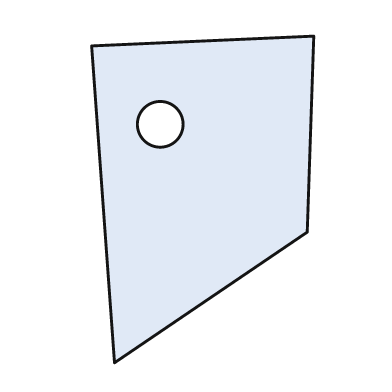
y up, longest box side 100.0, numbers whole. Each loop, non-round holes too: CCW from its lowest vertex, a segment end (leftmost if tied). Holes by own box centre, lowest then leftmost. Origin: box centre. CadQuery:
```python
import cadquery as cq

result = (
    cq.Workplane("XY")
    .moveTo(-27.0, -50.0)
    .lineTo(32.0, -10.0)
    .lineTo(34.0, 50.0)
    .lineTo(-34.0, 47.0)
    .close()
    .moveTo(-13.0, 23.0)
    .circle(7.0)
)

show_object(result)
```